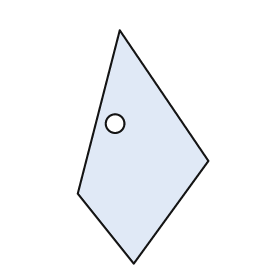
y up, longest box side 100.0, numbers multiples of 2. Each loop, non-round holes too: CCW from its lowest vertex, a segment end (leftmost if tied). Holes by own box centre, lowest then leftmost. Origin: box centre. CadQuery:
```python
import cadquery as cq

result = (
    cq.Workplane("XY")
    .moveTo(-4.0, -50.0)
    .lineTo(28.0, -6.0)
    .lineTo(-10.0, 50.0)
    .lineTo(-28.0, -20.0)
    .close()
    .moveTo(-12.0, 10.0)
    .circle(4.0)
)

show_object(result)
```